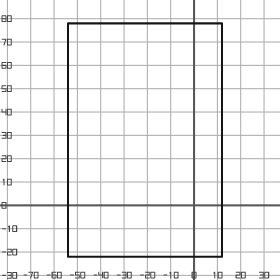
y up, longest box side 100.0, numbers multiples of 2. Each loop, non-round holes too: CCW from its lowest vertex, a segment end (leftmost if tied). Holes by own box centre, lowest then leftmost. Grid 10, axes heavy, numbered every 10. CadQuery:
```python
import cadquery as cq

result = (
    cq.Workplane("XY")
    .moveTo(-54.0, -22.0)
    .lineTo(12.0, -22.0)
    .lineTo(12.0, 78.0)
    .lineTo(-54.0, 78.0)
    .close()
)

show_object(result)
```